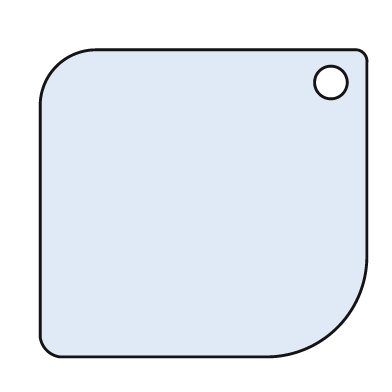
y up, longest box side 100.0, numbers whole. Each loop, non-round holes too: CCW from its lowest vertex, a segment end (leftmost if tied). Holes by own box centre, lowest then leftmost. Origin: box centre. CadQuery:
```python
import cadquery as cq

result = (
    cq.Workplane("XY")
    .moveTo(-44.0, -47.0)
    .lineTo(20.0, -47.0)
    .threePointArc((41.0, -38.0), (50.0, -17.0))
    .lineTo(50.0, 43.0)
    .threePointArc((49.0, 46.0), (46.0, 47.0))
    .lineTo(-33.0, 47.0)
    .threePointArc((-45.0, 42.0), (-50.0, 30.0))
    .lineTo(-50.0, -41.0)
    .threePointArc((-48.0, -45.0), (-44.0, -47.0))
    .close()
    .moveTo(39.0, 37.0)
    .circle(5.0)
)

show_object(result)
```